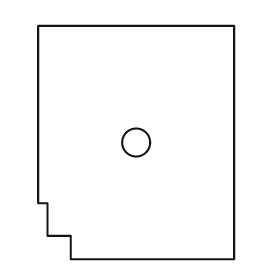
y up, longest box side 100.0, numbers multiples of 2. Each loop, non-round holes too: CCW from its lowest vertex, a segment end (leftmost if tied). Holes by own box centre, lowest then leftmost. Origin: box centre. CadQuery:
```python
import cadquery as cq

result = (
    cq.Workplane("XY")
    .moveTo(-28.0, -50.0)
    .lineTo(42.0, -50.0)
    .lineTo(42.0, 50.0)
    .lineTo(-42.0, 50.0)
    .lineTo(-42.0, -26.0)
    .lineTo(-38.0, -26.0)
    .lineTo(-38.0, -40.0)
    .lineTo(-28.0, -40.0)
    .close()
    .moveTo(0.0, 0.0)
    .circle(6.0)
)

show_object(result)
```